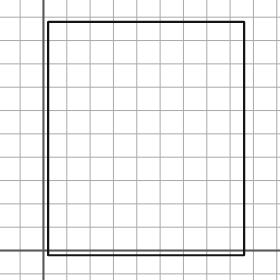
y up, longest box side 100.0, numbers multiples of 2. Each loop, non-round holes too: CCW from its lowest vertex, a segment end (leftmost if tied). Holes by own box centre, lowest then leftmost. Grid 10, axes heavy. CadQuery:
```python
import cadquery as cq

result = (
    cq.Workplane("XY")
    .moveTo(2.0, -2.0)
    .lineTo(86.0, -2.0)
    .lineTo(86.0, 98.0)
    .lineTo(2.0, 98.0)
    .close()
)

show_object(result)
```